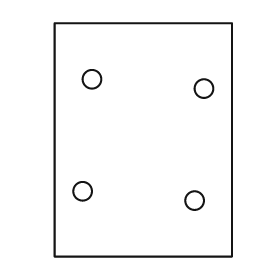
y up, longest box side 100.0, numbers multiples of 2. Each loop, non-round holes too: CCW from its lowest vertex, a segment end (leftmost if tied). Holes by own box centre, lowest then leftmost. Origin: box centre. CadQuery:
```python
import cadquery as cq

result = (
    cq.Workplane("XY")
    .moveTo(-38.0, -50.0)
    .lineTo(38.0, -50.0)
    .lineTo(38.0, 50.0)
    .lineTo(-38.0, 50.0)
    .close()
    .moveTo(22.0, -26.0)
    .circle(4.0)
    .moveTo(-26.0, -22.0)
    .circle(4.0)
    .moveTo(26.0, 22.0)
    .circle(4.0)
    .moveTo(-22.0, 26.0)
    .circle(4.0)
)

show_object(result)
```